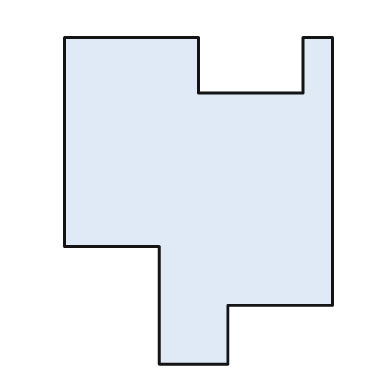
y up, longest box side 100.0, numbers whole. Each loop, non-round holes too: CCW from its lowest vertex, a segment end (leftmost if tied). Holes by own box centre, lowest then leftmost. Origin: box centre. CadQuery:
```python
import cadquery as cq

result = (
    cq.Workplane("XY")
    .moveTo(-12.0, -50.0)
    .lineTo(9.0, -50.0)
    .lineTo(9.0, -32.0)
    .lineTo(41.0, -32.0)
    .lineTo(41.0, 50.0)
    .lineTo(32.0, 50.0)
    .lineTo(32.0, 33.0)
    .lineTo(0.0, 33.0)
    .lineTo(0.0, 50.0)
    .lineTo(-41.0, 50.0)
    .lineTo(-41.0, -14.0)
    .lineTo(-12.0, -14.0)
    .close()
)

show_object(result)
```